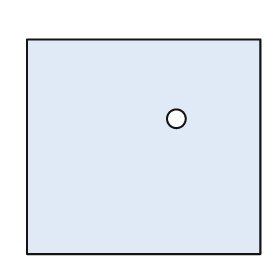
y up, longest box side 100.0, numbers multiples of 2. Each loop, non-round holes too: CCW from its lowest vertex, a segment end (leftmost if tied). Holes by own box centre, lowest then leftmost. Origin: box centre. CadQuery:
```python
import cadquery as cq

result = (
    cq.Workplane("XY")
    .moveTo(-50.0, -46.0)
    .lineTo(50.0, -46.0)
    .lineTo(50.0, 46.0)
    .lineTo(-50.0, 46.0)
    .close()
    .moveTo(14.0, 12.0)
    .circle(4.0)
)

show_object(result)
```